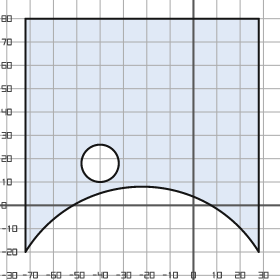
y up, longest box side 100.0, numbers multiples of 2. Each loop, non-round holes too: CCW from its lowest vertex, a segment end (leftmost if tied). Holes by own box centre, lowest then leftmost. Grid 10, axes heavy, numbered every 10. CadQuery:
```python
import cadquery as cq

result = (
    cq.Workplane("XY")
    .moveTo(-72.0, -20.0)
    .threePointArc((-22.0, 8.0), (28.0, -20.0))
    .lineTo(28.0, 80.0)
    .lineTo(-72.0, 80.0)
    .close()
    .moveTo(-40.0, 18.0)
    .circle(8.0)
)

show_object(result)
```